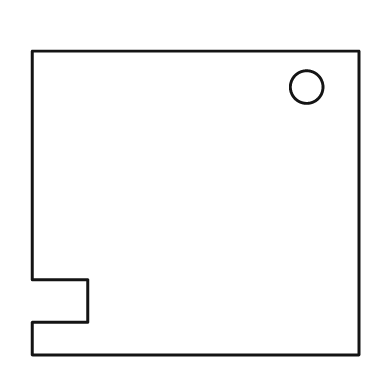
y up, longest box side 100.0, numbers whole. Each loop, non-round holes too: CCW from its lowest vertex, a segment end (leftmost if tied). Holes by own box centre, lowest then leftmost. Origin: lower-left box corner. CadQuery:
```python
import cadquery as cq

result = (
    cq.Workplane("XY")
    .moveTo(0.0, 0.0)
    .lineTo(100.0, 0.0)
    .lineTo(100.0, 93.0)
    .lineTo(0.0, 93.0)
    .lineTo(0.0, 23.0)
    .lineTo(17.0, 23.0)
    .lineTo(17.0, 10.0)
    .lineTo(0.0, 10.0)
    .close()
    .moveTo(84.0, 82.0)
    .circle(5.0)
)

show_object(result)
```